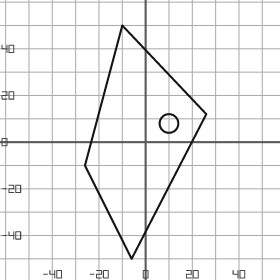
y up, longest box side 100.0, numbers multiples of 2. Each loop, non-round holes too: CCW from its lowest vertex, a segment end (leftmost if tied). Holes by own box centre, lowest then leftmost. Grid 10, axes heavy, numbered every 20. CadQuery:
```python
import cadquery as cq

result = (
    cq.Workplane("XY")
    .moveTo(-6.0, -50.0)
    .lineTo(26.0, 12.0)
    .lineTo(-10.0, 50.0)
    .lineTo(-26.0, -10.0)
    .close()
    .moveTo(10.0, 8.0)
    .circle(4.0)
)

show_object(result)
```